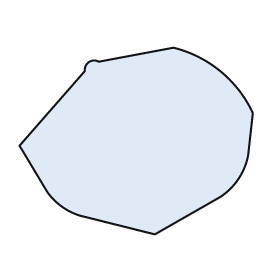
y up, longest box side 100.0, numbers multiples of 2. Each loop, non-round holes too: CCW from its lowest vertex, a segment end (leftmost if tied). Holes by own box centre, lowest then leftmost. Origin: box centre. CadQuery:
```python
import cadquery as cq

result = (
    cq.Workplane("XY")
    .moveTo(8.0, -40.0)
    .lineTo(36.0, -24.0)
    .threePointArc((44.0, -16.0), (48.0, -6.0))
    .lineTo(50.0, 12.0)
    .threePointArc((36.0, 30.0), (16.0, 40.0))
    .lineTo(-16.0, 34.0)
    .threePointArc((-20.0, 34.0), (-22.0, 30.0))
    .lineTo(-50.0, -2.0)
    .lineTo(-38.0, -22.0)
    .threePointArc((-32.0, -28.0), (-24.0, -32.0))
    .close()
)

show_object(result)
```